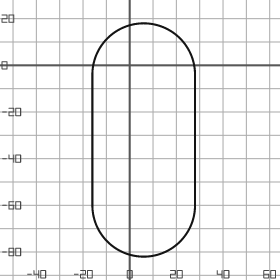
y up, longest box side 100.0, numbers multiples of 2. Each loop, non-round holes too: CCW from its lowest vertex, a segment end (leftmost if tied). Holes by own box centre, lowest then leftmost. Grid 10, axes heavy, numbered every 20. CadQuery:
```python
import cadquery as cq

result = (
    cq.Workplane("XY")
    .moveTo(-16.0, -60.0)
    .threePointArc((6.0, -82.0), (28.0, -60.0))
    .lineTo(28.0, -4.0)
    .threePointArc((6.0, 18.0), (-16.0, -4.0))
    .close()
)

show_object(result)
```